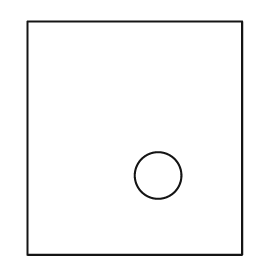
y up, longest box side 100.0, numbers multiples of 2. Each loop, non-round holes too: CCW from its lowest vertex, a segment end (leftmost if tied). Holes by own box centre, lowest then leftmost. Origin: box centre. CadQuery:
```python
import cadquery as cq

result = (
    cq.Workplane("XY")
    .moveTo(-46.0, -50.0)
    .lineTo(46.0, -50.0)
    .lineTo(46.0, 50.0)
    .lineTo(-46.0, 50.0)
    .close()
    .moveTo(10.0, -16.0)
    .circle(10.0)
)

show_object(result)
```